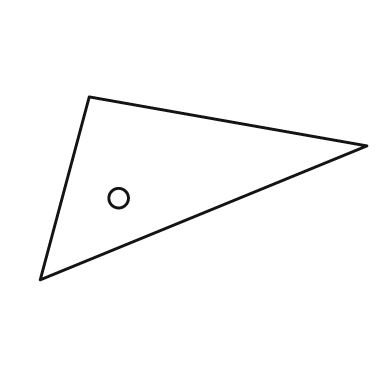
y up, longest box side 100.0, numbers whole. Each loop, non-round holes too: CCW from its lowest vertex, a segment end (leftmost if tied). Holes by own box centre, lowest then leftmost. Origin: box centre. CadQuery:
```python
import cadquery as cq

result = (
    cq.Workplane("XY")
    .moveTo(-50.0, -28.0)
    .lineTo(50.0, 13.0)
    .lineTo(-35.0, 28.0)
    .close()
    .moveTo(-26.0, -3.0)
    .circle(3.0)
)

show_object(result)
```